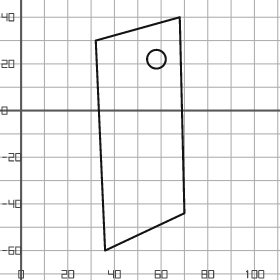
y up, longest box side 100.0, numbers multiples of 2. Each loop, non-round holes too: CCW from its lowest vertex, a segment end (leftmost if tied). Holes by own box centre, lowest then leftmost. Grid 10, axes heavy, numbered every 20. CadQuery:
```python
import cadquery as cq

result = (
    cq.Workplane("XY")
    .moveTo(36.0, -60.0)
    .lineTo(70.0, -44.0)
    .lineTo(68.0, 40.0)
    .lineTo(32.0, 30.0)
    .close()
    .moveTo(58.0, 22.0)
    .circle(4.0)
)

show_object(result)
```